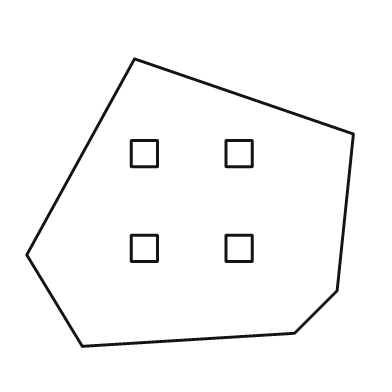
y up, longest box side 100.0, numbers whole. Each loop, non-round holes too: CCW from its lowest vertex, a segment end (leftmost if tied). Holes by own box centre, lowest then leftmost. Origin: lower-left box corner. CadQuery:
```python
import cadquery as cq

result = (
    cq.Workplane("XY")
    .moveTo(17.0, 0.0)
    .lineTo(82.0, 4.0)
    .lineTo(95.0, 17.0)
    .lineTo(100.0, 65.0)
    .lineTo(33.0, 88.0)
    .lineTo(0.0, 28.0)
    .close()
    .moveTo(32.0, 26.0)
    .lineTo(40.0, 26.0)
    .lineTo(40.0, 34.0)
    .lineTo(32.0, 34.0)
    .close()
    .moveTo(61.0, 26.0)
    .lineTo(69.0, 26.0)
    .lineTo(69.0, 34.0)
    .lineTo(61.0, 34.0)
    .close()
    .moveTo(32.0, 55.0)
    .lineTo(40.0, 55.0)
    .lineTo(40.0, 63.0)
    .lineTo(32.0, 63.0)
    .close()
    .moveTo(61.0, 55.0)
    .lineTo(69.0, 55.0)
    .lineTo(69.0, 63.0)
    .lineTo(61.0, 63.0)
    .close()
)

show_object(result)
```